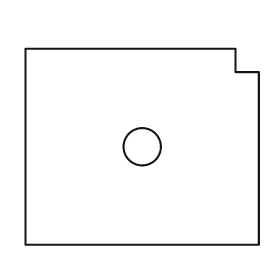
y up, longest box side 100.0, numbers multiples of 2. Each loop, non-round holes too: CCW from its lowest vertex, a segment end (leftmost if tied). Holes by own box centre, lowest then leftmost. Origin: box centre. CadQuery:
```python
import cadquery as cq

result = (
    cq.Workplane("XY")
    .moveTo(-50.0, -42.0)
    .lineTo(50.0, -42.0)
    .lineTo(50.0, 32.0)
    .lineTo(40.0, 32.0)
    .lineTo(40.0, 42.0)
    .lineTo(-50.0, 42.0)
    .close()
    .moveTo(0.0, 0.0)
    .circle(8.0)
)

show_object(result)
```